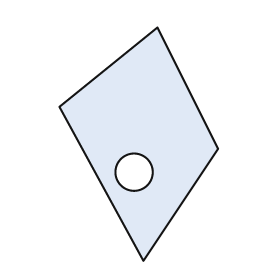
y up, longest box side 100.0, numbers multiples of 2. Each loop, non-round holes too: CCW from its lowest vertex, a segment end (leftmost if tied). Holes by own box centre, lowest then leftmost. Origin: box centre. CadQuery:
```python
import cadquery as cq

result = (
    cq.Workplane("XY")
    .moveTo(2.0, -50.0)
    .lineTo(34.0, -2.0)
    .lineTo(8.0, 50.0)
    .lineTo(-34.0, 16.0)
    .close()
    .moveTo(-2.0, -12.0)
    .circle(8.0)
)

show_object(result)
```